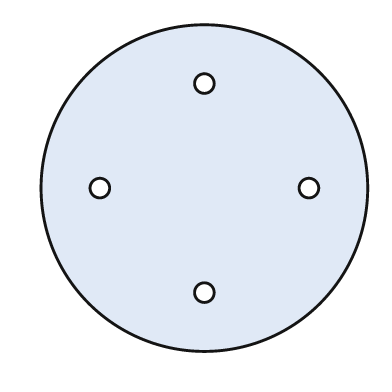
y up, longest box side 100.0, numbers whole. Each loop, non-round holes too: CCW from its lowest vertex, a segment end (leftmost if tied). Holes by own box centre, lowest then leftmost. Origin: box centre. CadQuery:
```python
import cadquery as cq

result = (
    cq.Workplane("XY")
    .moveTo(0.0, 0.0)
    .circle(50.0)
    .moveTo(0.0, -32.0)
    .circle(3.0)
    .moveTo(-32.0, 0.0)
    .circle(3.0)
    .moveTo(32.0, 0.0)
    .circle(3.0)
    .moveTo(0.0, 32.0)
    .circle(3.0)
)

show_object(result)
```